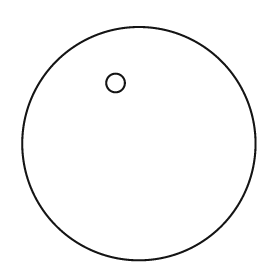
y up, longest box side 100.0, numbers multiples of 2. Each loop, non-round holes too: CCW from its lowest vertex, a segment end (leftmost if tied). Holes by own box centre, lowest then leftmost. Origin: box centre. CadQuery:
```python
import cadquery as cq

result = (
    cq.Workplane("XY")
    .moveTo(0.0, 0.0)
    .circle(50.0)
    .moveTo(-10.0, 26.0)
    .circle(4.0)
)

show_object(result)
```